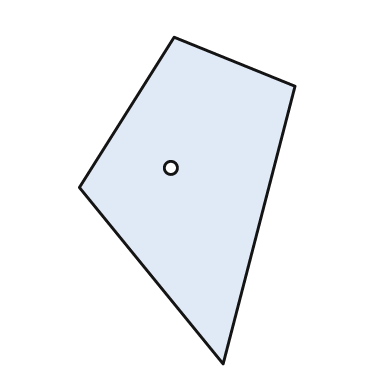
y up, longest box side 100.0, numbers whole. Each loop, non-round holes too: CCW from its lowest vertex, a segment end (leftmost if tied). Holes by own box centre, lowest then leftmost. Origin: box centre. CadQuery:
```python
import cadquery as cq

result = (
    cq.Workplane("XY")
    .moveTo(11.0, -50.0)
    .lineTo(33.0, 35.0)
    .lineTo(-4.0, 50.0)
    .lineTo(-33.0, 4.0)
    .close()
    .moveTo(-5.0, 10.0)
    .circle(2.0)
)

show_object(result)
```